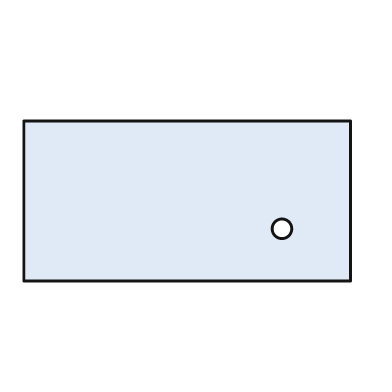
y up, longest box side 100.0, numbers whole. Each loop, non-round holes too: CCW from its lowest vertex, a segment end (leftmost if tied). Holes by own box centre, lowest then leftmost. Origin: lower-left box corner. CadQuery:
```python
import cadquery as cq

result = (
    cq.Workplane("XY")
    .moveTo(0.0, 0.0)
    .lineTo(100.0, 0.0)
    .lineTo(100.0, 49.0)
    .lineTo(0.0, 49.0)
    .close()
    .moveTo(79.0, 16.0)
    .circle(3.0)
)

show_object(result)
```